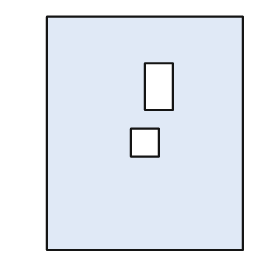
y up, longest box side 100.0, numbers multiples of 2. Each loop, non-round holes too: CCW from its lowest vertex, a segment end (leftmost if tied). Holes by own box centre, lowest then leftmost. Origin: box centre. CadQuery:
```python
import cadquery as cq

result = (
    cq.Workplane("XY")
    .moveTo(-42.0, -50.0)
    .lineTo(42.0, -50.0)
    .lineTo(42.0, 50.0)
    .lineTo(-42.0, 50.0)
    .close()
    .moveTo(-6.0, -10.0)
    .lineTo(6.0, -10.0)
    .lineTo(6.0, 2.0)
    .lineTo(-6.0, 2.0)
    .close()
    .moveTo(0.0, 10.0)
    .lineTo(12.0, 10.0)
    .lineTo(12.0, 30.0)
    .lineTo(0.0, 30.0)
    .close()
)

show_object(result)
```